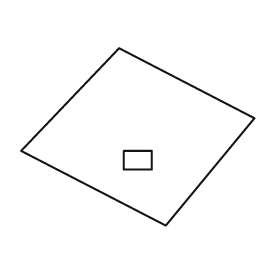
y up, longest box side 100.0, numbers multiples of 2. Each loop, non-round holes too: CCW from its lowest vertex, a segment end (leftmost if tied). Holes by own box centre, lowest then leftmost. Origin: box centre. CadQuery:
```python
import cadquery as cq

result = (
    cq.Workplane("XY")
    .moveTo(12.0, -38.0)
    .lineTo(50.0, 8.0)
    .lineTo(-8.0, 38.0)
    .lineTo(-50.0, -6.0)
    .close()
    .moveTo(-6.0, -14.0)
    .lineTo(6.0, -14.0)
    .lineTo(6.0, -6.0)
    .lineTo(-6.0, -6.0)
    .close()
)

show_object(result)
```